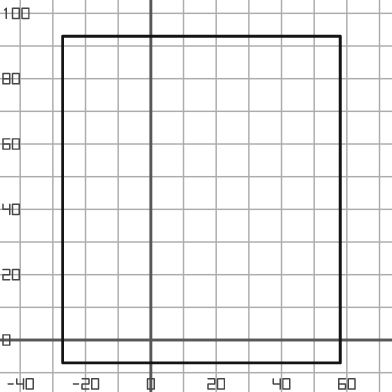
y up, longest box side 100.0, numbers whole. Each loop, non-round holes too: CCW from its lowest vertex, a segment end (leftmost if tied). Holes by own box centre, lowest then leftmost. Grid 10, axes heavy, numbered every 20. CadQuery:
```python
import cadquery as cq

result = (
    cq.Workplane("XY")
    .moveTo(-27.0, -7.0)
    .lineTo(58.0, -7.0)
    .lineTo(58.0, 93.0)
    .lineTo(-27.0, 93.0)
    .close()
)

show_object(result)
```